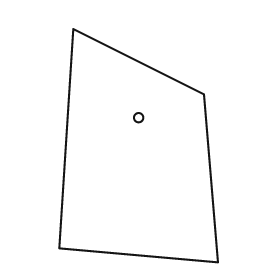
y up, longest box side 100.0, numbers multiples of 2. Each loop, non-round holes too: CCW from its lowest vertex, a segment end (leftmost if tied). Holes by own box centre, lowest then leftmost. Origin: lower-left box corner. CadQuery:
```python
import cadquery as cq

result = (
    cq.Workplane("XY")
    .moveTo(68.0, 0.0)
    .lineTo(62.0, 72.0)
    .lineTo(6.0, 100.0)
    .lineTo(0.0, 6.0)
    .close()
    .moveTo(34.0, 62.0)
    .circle(2.0)
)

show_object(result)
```